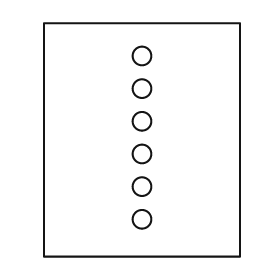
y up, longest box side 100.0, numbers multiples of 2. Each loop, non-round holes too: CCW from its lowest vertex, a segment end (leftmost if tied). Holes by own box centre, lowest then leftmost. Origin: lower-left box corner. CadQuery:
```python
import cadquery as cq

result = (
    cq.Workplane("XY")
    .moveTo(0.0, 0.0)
    .lineTo(84.0, 0.0)
    .lineTo(84.0, 100.0)
    .lineTo(0.0, 100.0)
    .close()
    .moveTo(42.0, 16.0)
    .circle(4.0)
    .moveTo(42.0, 30.0)
    .circle(4.0)
    .moveTo(42.0, 44.0)
    .circle(4.0)
    .moveTo(42.0, 58.0)
    .circle(4.0)
    .moveTo(42.0, 72.0)
    .circle(4.0)
    .moveTo(42.0, 86.0)
    .circle(4.0)
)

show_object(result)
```